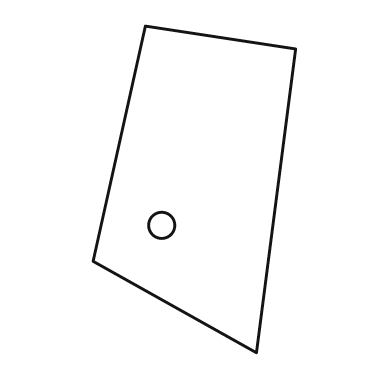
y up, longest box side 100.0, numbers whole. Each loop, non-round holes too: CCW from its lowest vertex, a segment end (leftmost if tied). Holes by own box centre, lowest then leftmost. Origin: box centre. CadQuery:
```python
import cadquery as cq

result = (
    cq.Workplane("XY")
    .moveTo(19.0, -50.0)
    .lineTo(31.0, 43.0)
    .lineTo(-15.0, 50.0)
    .lineTo(-31.0, -22.0)
    .close()
    .moveTo(-10.0, -11.0)
    .circle(4.0)
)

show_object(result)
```